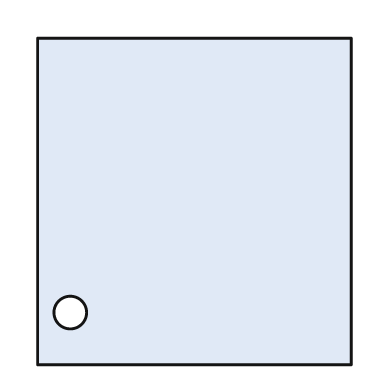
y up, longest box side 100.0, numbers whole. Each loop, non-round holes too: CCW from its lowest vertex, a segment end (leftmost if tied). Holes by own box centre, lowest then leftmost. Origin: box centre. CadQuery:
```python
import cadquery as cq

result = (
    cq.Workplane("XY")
    .moveTo(-48.0, -50.0)
    .lineTo(48.0, -50.0)
    .lineTo(48.0, 50.0)
    .lineTo(-48.0, 50.0)
    .close()
    .moveTo(-38.0, -34.0)
    .circle(5.0)
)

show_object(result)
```